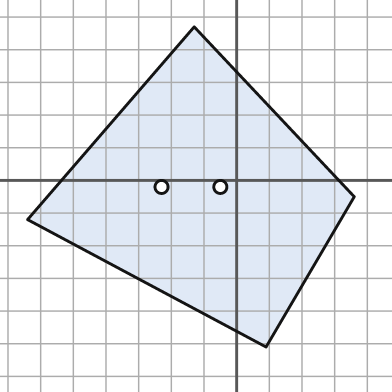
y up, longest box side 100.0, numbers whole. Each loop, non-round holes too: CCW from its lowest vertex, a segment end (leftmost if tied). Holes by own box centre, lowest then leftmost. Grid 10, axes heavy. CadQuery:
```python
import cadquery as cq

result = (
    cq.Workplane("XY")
    .moveTo(9.0, -51.0)
    .lineTo(36.0, -5.0)
    .lineTo(-13.0, 47.0)
    .lineTo(-64.0, -12.0)
    .close()
    .moveTo(-23.0, -2.0)
    .circle(2.0)
    .moveTo(-5.0, -2.0)
    .circle(2.0)
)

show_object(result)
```